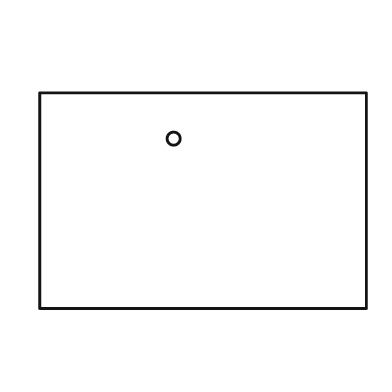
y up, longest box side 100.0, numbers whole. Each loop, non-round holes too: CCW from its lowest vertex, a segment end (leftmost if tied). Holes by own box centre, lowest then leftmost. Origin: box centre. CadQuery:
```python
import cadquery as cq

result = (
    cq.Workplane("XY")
    .moveTo(-50.0, -33.0)
    .lineTo(50.0, -33.0)
    .lineTo(50.0, 33.0)
    .lineTo(-50.0, 33.0)
    .close()
    .moveTo(-9.0, 19.0)
    .circle(2.0)
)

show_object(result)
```